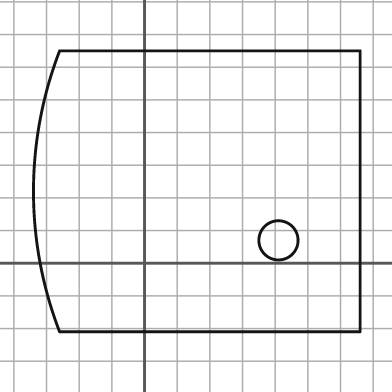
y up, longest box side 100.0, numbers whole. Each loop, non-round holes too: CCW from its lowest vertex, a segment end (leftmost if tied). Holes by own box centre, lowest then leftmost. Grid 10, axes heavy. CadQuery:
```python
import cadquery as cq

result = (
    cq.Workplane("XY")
    .moveTo(-26.0, -21.0)
    .lineTo(66.0, -21.0)
    .lineTo(66.0, 65.0)
    .lineTo(-26.0, 65.0)
    .threePointArc((-34.0, 22.0), (-26.0, -21.0))
    .close()
    .moveTo(41.0, 7.0)
    .circle(6.0)
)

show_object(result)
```